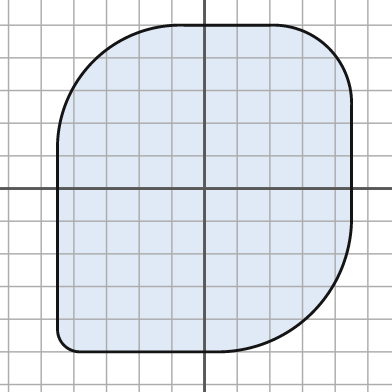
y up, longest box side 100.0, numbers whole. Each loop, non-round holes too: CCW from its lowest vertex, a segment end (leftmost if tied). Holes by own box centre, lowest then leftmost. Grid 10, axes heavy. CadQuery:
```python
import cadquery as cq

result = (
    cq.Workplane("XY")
    .moveTo(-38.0, -50.0)
    .lineTo(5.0, -50.0)
    .threePointArc((33.0, -38.0), (45.0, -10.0))
    .lineTo(45.0, 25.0)
    .threePointArc((38.0, 43.0), (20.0, 50.0))
    .lineTo(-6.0, 50.0)
    .threePointArc((-34.0, 39.0), (-45.0, 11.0))
    .lineTo(-45.0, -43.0)
    .threePointArc((-43.0, -48.0), (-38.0, -50.0))
    .close()
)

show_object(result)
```